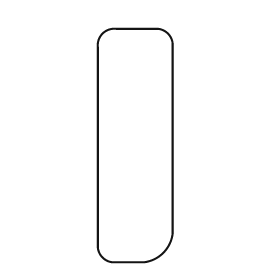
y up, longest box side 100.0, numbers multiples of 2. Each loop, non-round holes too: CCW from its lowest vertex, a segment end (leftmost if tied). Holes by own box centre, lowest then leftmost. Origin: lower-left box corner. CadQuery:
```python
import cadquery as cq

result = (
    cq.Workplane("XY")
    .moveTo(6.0, 0.0)
    .lineTo(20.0, 0.0)
    .threePointArc((28.0, 4.0), (32.0, 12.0))
    .lineTo(32.0, 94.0)
    .threePointArc((30.0, 98.0), (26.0, 100.0))
    .lineTo(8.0, 100.0)
    .threePointArc((2.0, 98.0), (0.0, 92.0))
    .lineTo(0.0, 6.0)
    .threePointArc((2.0, 2.0), (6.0, 0.0))
    .close()
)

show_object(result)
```